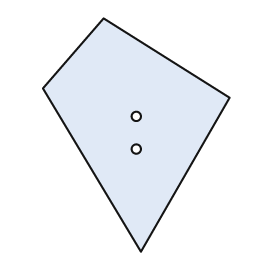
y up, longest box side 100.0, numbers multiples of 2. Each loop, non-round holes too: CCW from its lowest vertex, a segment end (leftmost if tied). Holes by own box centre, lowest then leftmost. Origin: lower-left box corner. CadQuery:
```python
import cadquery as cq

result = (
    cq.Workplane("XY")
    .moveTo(42.0, 0.0)
    .lineTo(80.0, 66.0)
    .lineTo(26.0, 100.0)
    .lineTo(0.0, 70.0)
    .close()
    .moveTo(40.0, 44.0)
    .circle(2.0)
    .moveTo(40.0, 58.0)
    .circle(2.0)
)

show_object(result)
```